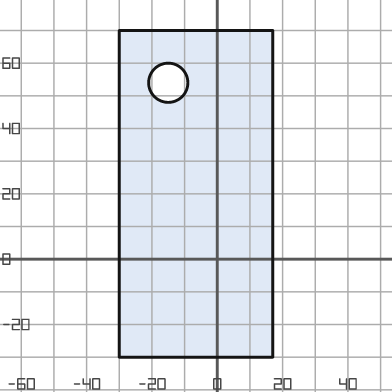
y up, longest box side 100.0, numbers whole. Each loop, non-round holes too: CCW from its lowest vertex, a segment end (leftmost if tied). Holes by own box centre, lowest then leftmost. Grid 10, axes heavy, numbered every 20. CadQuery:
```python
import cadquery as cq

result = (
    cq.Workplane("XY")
    .moveTo(-30.0, -30.0)
    .lineTo(17.0, -30.0)
    .lineTo(17.0, 70.0)
    .lineTo(-30.0, 70.0)
    .close()
    .moveTo(-15.0, 54.0)
    .circle(6.0)
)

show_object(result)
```